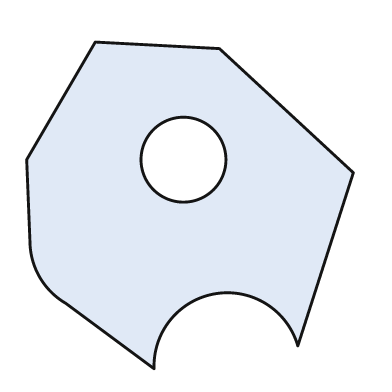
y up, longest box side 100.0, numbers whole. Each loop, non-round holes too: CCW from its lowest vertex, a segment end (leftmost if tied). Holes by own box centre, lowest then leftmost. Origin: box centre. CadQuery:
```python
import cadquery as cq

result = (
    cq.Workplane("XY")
    .moveTo(-11.0, -50.0)
    .threePointArc((8.0, -27.0), (33.0, -43.0))
    .lineTo(50.0, 10.0)
    .lineTo(9.0, 48.0)
    .lineTo(-29.0, 50.0)
    .lineTo(-50.0, 14.0)
    .lineTo(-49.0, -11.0)
    .threePointArc((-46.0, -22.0), (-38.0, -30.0))
    .close()
    .moveTo(-2.0, 14.0)
    .circle(13.0)
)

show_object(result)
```